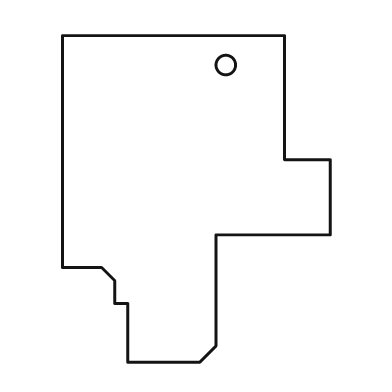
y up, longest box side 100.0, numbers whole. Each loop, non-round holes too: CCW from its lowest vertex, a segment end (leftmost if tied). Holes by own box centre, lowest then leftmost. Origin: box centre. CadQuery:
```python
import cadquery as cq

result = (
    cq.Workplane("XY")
    .moveTo(-21.0, -50.0)
    .lineTo(1.0, -50.0)
    .lineTo(6.0, -45.0)
    .lineTo(6.0, -11.0)
    .lineTo(41.0, -11.0)
    .lineTo(41.0, 12.0)
    .lineTo(27.0, 12.0)
    .lineTo(27.0, 50.0)
    .lineTo(-41.0, 50.0)
    .lineTo(-41.0, -21.0)
    .lineTo(-29.0, -21.0)
    .lineTo(-25.0, -25.0)
    .lineTo(-25.0, -32.0)
    .lineTo(-21.0, -32.0)
    .close()
    .moveTo(9.0, 41.0)
    .circle(3.0)
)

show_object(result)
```